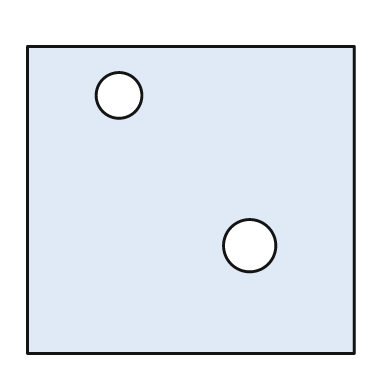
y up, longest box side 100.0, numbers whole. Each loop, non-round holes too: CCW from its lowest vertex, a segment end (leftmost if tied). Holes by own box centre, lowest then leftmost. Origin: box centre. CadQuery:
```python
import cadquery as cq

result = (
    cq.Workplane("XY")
    .moveTo(-50.0, -47.0)
    .lineTo(50.0, -47.0)
    .lineTo(50.0, 47.0)
    .lineTo(-50.0, 47.0)
    .close()
    .moveTo(18.0, -14.0)
    .circle(8.0)
    .moveTo(-22.0, 32.0)
    .circle(7.0)
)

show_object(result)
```